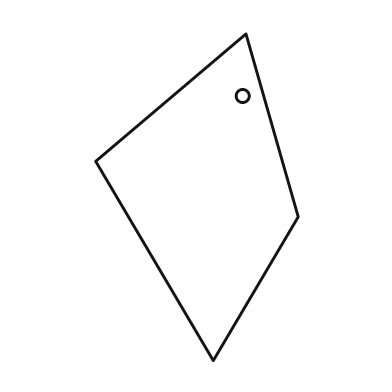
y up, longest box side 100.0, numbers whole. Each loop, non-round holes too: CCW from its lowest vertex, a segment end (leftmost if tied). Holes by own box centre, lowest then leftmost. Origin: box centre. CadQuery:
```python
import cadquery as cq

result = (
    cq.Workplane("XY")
    .moveTo(5.0, -50.0)
    .lineTo(31.0, -6.0)
    .lineTo(15.0, 50.0)
    .lineTo(-31.0, 11.0)
    .close()
    .moveTo(14.0, 31.0)
    .circle(2.0)
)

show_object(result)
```